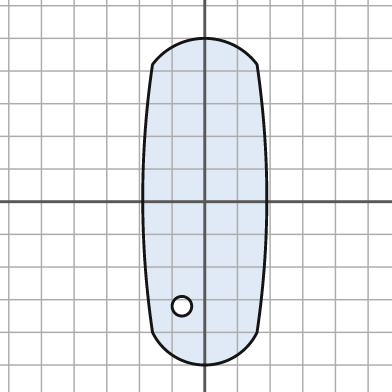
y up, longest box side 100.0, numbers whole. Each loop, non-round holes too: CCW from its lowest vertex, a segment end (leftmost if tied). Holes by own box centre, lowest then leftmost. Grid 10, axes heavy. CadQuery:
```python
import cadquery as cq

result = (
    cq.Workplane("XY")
    .moveTo(-16.0, -40.0)
    .threePointArc((0.0, -50.0), (16.0, -40.0))
    .threePointArc((19.0, 1.0), (16.0, 42.0))
    .threePointArc((0.0, 50.0), (-16.0, 42.0))
    .threePointArc((-19.0, 1.0), (-16.0, -40.0))
    .close()
    .moveTo(-7.0, -32.0)
    .circle(3.0)
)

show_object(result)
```